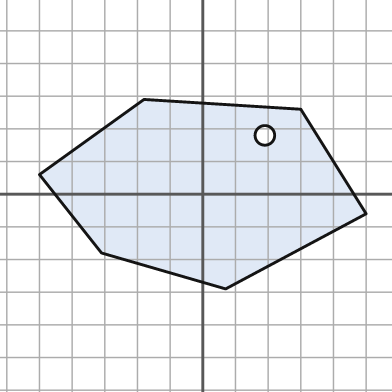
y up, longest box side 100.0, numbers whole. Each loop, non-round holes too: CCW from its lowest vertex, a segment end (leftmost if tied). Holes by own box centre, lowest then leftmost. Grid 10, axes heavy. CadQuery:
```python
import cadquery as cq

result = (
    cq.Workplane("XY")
    .moveTo(7.0, -29.0)
    .lineTo(50.0, -6.0)
    .lineTo(30.0, 26.0)
    .lineTo(-18.0, 29.0)
    .lineTo(-50.0, 6.0)
    .lineTo(-31.0, -18.0)
    .close()
    .moveTo(19.0, 18.0)
    .circle(3.0)
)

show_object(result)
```